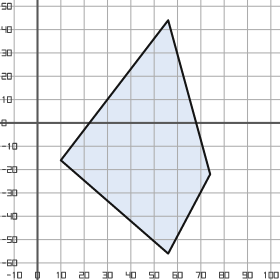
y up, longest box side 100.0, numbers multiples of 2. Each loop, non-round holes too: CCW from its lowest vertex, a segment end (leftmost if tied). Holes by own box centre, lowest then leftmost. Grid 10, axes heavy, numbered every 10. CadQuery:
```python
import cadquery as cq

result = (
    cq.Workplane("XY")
    .moveTo(56.0, -56.0)
    .lineTo(74.0, -22.0)
    .lineTo(56.0, 44.0)
    .lineTo(10.0, -16.0)
    .close()
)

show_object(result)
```